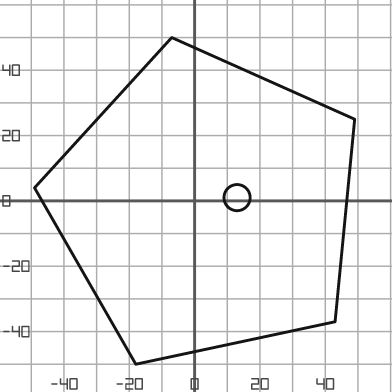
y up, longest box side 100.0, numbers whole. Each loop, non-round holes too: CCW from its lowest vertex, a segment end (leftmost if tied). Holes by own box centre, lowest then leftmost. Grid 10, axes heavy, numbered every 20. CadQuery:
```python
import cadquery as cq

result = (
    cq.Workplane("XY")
    .moveTo(-18.0, -50.0)
    .lineTo(43.0, -37.0)
    .lineTo(49.0, 25.0)
    .lineTo(-7.0, 50.0)
    .lineTo(-49.0, 4.0)
    .close()
    .moveTo(13.0, 1.0)
    .circle(4.0)
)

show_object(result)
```